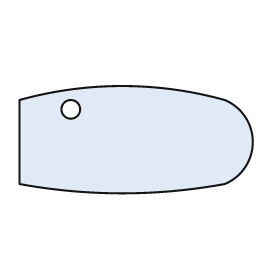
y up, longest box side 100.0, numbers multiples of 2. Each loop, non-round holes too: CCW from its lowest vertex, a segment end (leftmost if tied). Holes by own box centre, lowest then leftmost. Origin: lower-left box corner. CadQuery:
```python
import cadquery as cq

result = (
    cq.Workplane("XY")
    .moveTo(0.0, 4.0)
    .threePointArc((44.0, 0.0), (88.0, 4.0))
    .threePointArc((100.0, 22.0), (88.0, 40.0))
    .threePointArc((44.0, 46.0), (0.0, 40.0))
    .close()
    .moveTo(22.0, 36.0)
    .circle(4.0)
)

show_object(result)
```